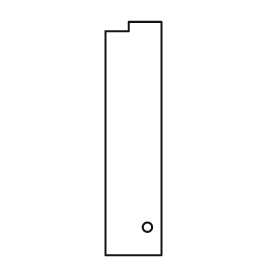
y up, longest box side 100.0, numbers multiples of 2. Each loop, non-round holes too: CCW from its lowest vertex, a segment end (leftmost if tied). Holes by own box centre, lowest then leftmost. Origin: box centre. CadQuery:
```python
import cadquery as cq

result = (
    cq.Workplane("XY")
    .moveTo(-12.0, -50.0)
    .lineTo(12.0, -50.0)
    .lineTo(12.0, 50.0)
    .lineTo(-2.0, 50.0)
    .lineTo(-2.0, 46.0)
    .lineTo(-12.0, 46.0)
    .close()
    .moveTo(6.0, -38.0)
    .circle(2.0)
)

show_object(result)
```